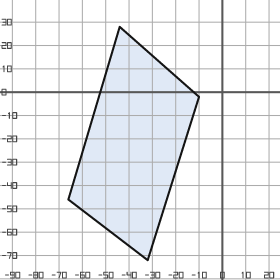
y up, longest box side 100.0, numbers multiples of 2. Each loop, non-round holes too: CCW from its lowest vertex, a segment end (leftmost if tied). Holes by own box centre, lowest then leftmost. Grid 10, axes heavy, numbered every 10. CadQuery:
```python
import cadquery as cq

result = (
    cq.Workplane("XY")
    .moveTo(-32.0, -72.0)
    .lineTo(-10.0, -2.0)
    .lineTo(-44.0, 28.0)
    .lineTo(-66.0, -46.0)
    .close()
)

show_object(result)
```